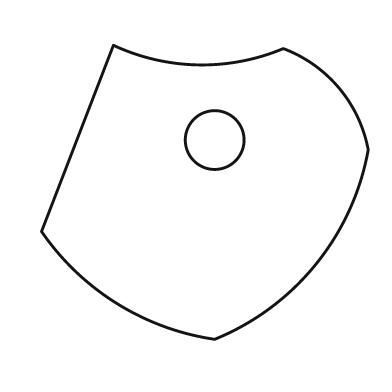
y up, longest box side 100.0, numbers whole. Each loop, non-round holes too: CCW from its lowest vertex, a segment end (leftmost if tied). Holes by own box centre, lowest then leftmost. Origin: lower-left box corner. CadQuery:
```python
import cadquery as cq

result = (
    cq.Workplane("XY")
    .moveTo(53.0, 0.0)
    .threePointArc((84.0, 23.0), (100.0, 58.0))
    .threePointArc((91.0, 77.0), (74.0, 89.0))
    .threePointArc((48.0, 84.0), (22.0, 90.0))
    .lineTo(0.0, 33.0)
    .threePointArc((23.0, 11.0), (53.0, 0.0))
    .close()
    .moveTo(53.0, 61.0)
    .circle(9.0)
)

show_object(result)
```